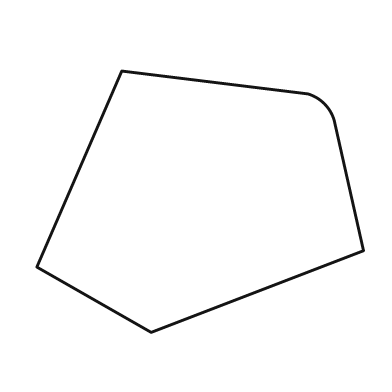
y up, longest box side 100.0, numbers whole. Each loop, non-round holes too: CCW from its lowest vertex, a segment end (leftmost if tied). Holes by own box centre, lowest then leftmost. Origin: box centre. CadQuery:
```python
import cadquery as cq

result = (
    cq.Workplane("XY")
    .moveTo(-15.0, -40.0)
    .lineTo(50.0, -15.0)
    .lineTo(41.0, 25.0)
    .threePointArc((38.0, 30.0), (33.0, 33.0))
    .lineTo(-24.0, 40.0)
    .lineTo(-50.0, -20.0)
    .close()
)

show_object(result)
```